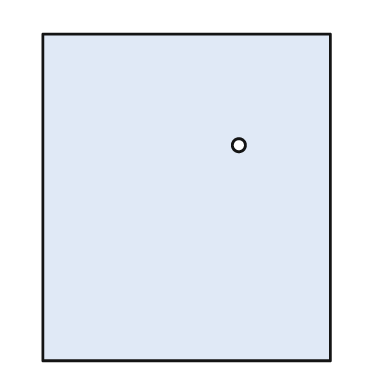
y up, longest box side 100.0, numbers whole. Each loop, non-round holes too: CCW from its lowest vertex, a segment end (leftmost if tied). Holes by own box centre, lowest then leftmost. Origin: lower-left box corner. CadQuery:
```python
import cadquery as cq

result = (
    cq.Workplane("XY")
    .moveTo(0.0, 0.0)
    .lineTo(88.0, 0.0)
    .lineTo(88.0, 100.0)
    .lineTo(0.0, 100.0)
    .close()
    .moveTo(60.0, 66.0)
    .circle(2.0)
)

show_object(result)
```